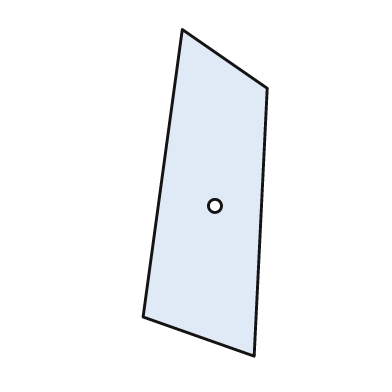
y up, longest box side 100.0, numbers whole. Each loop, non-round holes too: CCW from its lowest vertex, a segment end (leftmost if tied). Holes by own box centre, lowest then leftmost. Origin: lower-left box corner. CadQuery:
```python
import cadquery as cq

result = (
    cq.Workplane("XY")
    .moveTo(34.0, 0.0)
    .lineTo(38.0, 82.0)
    .lineTo(12.0, 100.0)
    .lineTo(0.0, 12.0)
    .close()
    .moveTo(22.0, 46.0)
    .circle(2.0)
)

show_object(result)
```